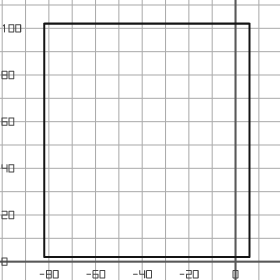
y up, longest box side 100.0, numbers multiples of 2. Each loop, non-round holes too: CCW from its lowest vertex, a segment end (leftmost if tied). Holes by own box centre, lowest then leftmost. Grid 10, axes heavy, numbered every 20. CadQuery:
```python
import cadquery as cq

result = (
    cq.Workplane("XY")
    .moveTo(-82.0, 2.0)
    .lineTo(6.0, 2.0)
    .lineTo(6.0, 102.0)
    .lineTo(-82.0, 102.0)
    .close()
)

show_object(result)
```